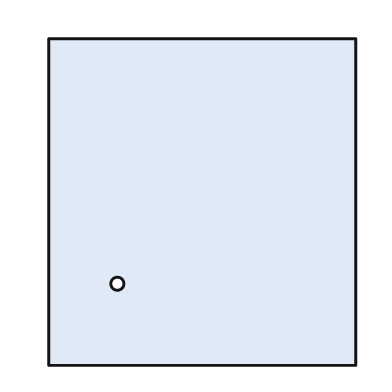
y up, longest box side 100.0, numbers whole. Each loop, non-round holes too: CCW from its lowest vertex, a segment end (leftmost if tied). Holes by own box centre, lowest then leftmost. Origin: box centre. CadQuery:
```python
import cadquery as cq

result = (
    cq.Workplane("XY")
    .moveTo(-47.0, -50.0)
    .lineTo(47.0, -50.0)
    .lineTo(47.0, 50.0)
    .lineTo(-47.0, 50.0)
    .close()
    .moveTo(-26.0, -25.0)
    .circle(2.0)
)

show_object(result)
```